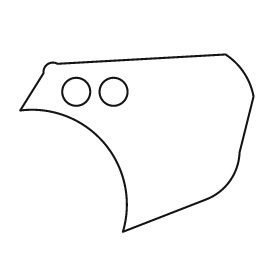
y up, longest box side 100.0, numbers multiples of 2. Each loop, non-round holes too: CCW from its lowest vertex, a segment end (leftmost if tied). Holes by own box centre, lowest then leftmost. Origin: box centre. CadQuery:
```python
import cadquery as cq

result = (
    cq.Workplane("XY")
    .moveTo(-6.0, -38.0)
    .lineTo(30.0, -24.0)
    .threePointArc((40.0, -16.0), (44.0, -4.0))
    .lineTo(50.0, 20.0)
    .threePointArc((46.0, 30.0), (38.0, 38.0))
    .lineTo(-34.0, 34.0)
    .threePointArc((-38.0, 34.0), (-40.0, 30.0))
    .lineTo(-50.0, 14.0)
    .threePointArc((-14.0, 0.0), (-6.0, -38.0))
    .close()
    .moveTo(-26.0, 22.0)
    .circle(6.0)
    .moveTo(-10.0, 22.0)
    .circle(6.0)
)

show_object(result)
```